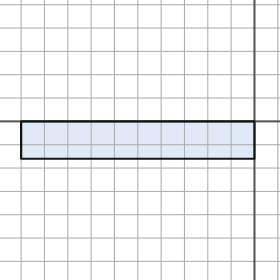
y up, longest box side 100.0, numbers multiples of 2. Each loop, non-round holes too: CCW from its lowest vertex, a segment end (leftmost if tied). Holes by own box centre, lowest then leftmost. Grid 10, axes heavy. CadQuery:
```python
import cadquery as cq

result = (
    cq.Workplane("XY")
    .moveTo(-100.0, -16.0)
    .lineTo(0.0, -16.0)
    .lineTo(0.0, 0.0)
    .lineTo(-100.0, 0.0)
    .close()
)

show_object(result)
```